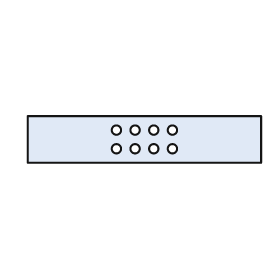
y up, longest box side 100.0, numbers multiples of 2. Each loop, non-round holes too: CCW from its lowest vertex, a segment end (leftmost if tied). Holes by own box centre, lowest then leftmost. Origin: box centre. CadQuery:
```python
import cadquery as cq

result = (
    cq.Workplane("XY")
    .moveTo(-50.0, -10.0)
    .lineTo(50.0, -10.0)
    .lineTo(50.0, 10.0)
    .lineTo(-50.0, 10.0)
    .close()
    .moveTo(-12.0, -4.0)
    .circle(2.0)
    .moveTo(-4.0, -4.0)
    .circle(2.0)
    .moveTo(4.0, -4.0)
    .circle(2.0)
    .moveTo(12.0, -4.0)
    .circle(2.0)
    .moveTo(-12.0, 4.0)
    .circle(2.0)
    .moveTo(-4.0, 4.0)
    .circle(2.0)
    .moveTo(4.0, 4.0)
    .circle(2.0)
    .moveTo(12.0, 4.0)
    .circle(2.0)
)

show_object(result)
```